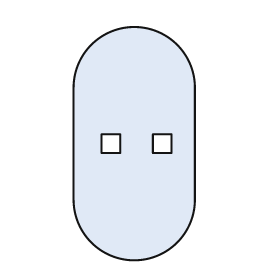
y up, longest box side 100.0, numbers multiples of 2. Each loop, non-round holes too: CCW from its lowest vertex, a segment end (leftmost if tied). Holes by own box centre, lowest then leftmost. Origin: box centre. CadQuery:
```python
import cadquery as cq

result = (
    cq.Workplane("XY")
    .moveTo(-26.0, -24.0)
    .threePointArc((0.0, -50.0), (26.0, -24.0))
    .lineTo(26.0, 24.0)
    .threePointArc((0.0, 50.0), (-26.0, 24.0))
    .close()
    .moveTo(-14.0, -4.0)
    .lineTo(-6.0, -4.0)
    .lineTo(-6.0, 4.0)
    .lineTo(-14.0, 4.0)
    .close()
    .moveTo(8.0, -4.0)
    .lineTo(16.0, -4.0)
    .lineTo(16.0, 4.0)
    .lineTo(8.0, 4.0)
    .close()
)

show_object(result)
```